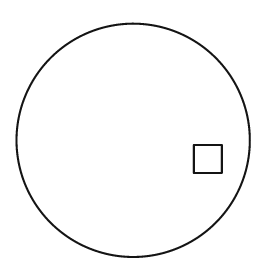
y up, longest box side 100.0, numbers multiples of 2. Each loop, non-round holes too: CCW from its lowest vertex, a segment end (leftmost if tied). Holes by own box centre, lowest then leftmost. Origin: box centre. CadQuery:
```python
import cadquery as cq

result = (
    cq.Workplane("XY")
    .moveTo(0.0, 0.0)
    .circle(50.0)
    .moveTo(26.0, -14.0)
    .lineTo(38.0, -14.0)
    .lineTo(38.0, -2.0)
    .lineTo(26.0, -2.0)
    .close()
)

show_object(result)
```